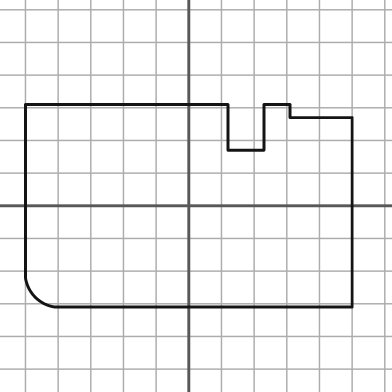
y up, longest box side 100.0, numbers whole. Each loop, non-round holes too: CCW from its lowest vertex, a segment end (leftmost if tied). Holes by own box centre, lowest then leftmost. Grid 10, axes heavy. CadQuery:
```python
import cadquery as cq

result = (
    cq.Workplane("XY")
    .moveTo(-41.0, -31.0)
    .lineTo(50.0, -31.0)
    .lineTo(50.0, 27.0)
    .lineTo(31.0, 27.0)
    .lineTo(31.0, 31.0)
    .lineTo(23.0, 31.0)
    .lineTo(23.0, 17.0)
    .lineTo(12.0, 17.0)
    .lineTo(12.0, 31.0)
    .lineTo(-50.0, 31.0)
    .lineTo(-50.0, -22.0)
    .threePointArc((-47.0, -28.0), (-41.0, -31.0))
    .close()
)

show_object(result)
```